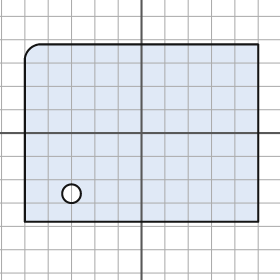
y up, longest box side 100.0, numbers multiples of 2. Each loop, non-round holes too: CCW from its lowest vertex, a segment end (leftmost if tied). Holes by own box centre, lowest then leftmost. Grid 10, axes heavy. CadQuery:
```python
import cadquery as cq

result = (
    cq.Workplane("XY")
    .moveTo(-50.0, -38.0)
    .lineTo(50.0, -38.0)
    .lineTo(50.0, 38.0)
    .lineTo(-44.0, 38.0)
    .threePointArc((-48.0, 36.0), (-50.0, 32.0))
    .close()
    .moveTo(-30.0, -26.0)
    .circle(4.0)
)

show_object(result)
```